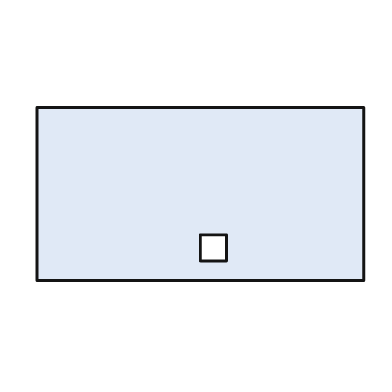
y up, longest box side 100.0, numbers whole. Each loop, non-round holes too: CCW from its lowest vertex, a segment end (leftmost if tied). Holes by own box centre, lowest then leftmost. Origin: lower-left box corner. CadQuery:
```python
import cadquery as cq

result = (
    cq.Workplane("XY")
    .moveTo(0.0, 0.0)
    .lineTo(100.0, 0.0)
    .lineTo(100.0, 53.0)
    .lineTo(0.0, 53.0)
    .close()
    .moveTo(50.0, 6.0)
    .lineTo(58.0, 6.0)
    .lineTo(58.0, 14.0)
    .lineTo(50.0, 14.0)
    .close()
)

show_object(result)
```